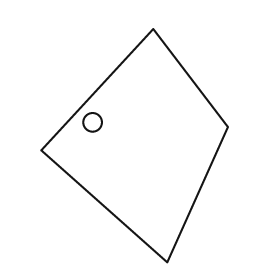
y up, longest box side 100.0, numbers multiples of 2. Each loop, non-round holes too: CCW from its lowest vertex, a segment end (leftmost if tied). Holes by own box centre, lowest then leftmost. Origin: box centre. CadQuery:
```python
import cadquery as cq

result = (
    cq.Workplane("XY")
    .moveTo(14.0, -50.0)
    .lineTo(40.0, 8.0)
    .lineTo(8.0, 50.0)
    .lineTo(-40.0, -2.0)
    .close()
    .moveTo(-18.0, 10.0)
    .circle(4.0)
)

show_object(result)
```